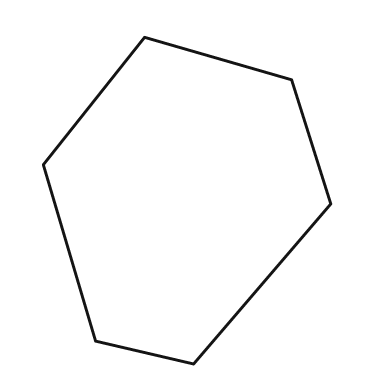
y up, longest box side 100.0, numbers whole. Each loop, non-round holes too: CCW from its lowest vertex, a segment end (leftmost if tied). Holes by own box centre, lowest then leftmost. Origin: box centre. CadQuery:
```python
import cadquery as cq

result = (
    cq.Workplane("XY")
    .moveTo(2.0, -50.0)
    .lineTo(44.0, -1.0)
    .lineTo(32.0, 37.0)
    .lineTo(-13.0, 50.0)
    .lineTo(-44.0, 11.0)
    .lineTo(-28.0, -43.0)
    .close()
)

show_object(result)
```